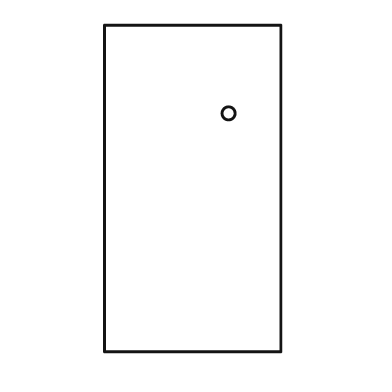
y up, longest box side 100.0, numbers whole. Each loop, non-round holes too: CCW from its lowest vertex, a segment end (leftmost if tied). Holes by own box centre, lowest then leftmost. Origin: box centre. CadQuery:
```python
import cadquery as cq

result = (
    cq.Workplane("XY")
    .moveTo(-27.0, -50.0)
    .lineTo(27.0, -50.0)
    .lineTo(27.0, 50.0)
    .lineTo(-27.0, 50.0)
    .close()
    .moveTo(11.0, 23.0)
    .circle(2.0)
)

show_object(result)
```